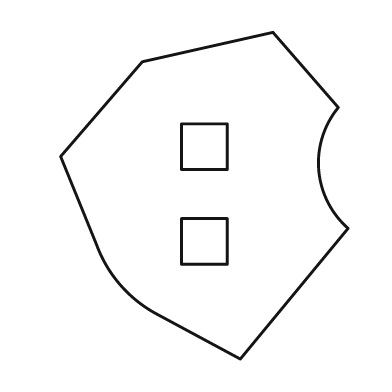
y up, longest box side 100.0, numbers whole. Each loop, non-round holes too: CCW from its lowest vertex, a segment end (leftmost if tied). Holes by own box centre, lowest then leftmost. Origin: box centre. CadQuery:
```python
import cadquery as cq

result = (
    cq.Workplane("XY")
    .moveTo(11.0, -50.0)
    .lineTo(44.0, -10.0)
    .threePointArc((35.0, 8.0), (41.0, 27.0))
    .lineTo(21.0, 50.0)
    .lineTo(-19.0, 41.0)
    .lineTo(-44.0, 12.0)
    .lineTo(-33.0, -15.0)
    .threePointArc((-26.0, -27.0), (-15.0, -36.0))
    .close()
    .moveTo(-7.0, -21.0)
    .lineTo(7.0, -21.0)
    .lineTo(7.0, -7.0)
    .lineTo(-7.0, -7.0)
    .close()
    .moveTo(-7.0, 8.0)
    .lineTo(7.0, 8.0)
    .lineTo(7.0, 22.0)
    .lineTo(-7.0, 22.0)
    .close()
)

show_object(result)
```